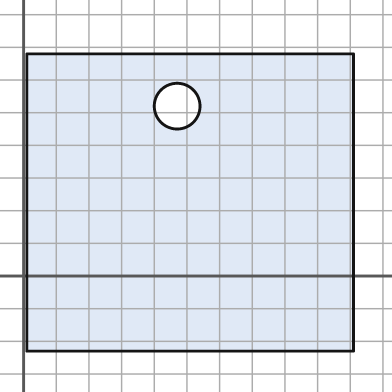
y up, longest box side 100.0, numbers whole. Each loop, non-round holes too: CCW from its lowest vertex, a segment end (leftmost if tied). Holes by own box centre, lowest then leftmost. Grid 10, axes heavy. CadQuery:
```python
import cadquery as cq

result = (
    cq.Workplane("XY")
    .moveTo(1.0, -23.0)
    .lineTo(101.0, -23.0)
    .lineTo(101.0, 68.0)
    .lineTo(1.0, 68.0)
    .close()
    .moveTo(47.0, 52.0)
    .circle(7.0)
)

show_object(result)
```